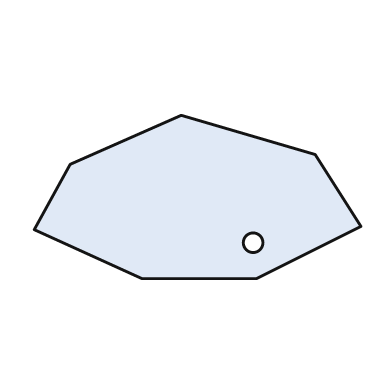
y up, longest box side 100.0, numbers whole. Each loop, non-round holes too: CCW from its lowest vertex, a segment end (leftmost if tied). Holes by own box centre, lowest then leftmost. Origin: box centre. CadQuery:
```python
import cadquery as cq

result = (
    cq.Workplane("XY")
    .moveTo(-17.0, -25.0)
    .lineTo(18.0, -25.0)
    .lineTo(50.0, -9.0)
    .lineTo(36.0, 13.0)
    .lineTo(-5.0, 25.0)
    .lineTo(-39.0, 10.0)
    .lineTo(-50.0, -10.0)
    .close()
    .moveTo(17.0, -14.0)
    .circle(3.0)
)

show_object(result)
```